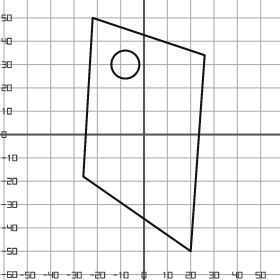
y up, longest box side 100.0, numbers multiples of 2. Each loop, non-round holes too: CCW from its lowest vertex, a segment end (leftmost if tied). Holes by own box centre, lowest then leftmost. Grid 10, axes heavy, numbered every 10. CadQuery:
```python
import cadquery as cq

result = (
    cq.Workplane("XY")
    .moveTo(20.0, -50.0)
    .lineTo(26.0, 34.0)
    .lineTo(-22.0, 50.0)
    .lineTo(-26.0, -18.0)
    .close()
    .moveTo(-8.0, 30.0)
    .circle(6.0)
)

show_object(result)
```